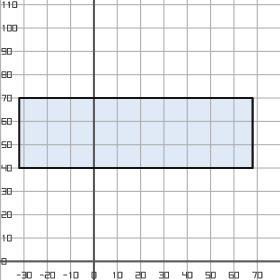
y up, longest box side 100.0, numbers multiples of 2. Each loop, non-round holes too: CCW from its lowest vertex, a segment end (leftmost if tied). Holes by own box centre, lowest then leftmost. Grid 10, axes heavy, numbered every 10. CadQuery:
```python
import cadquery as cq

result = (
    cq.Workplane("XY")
    .moveTo(-32.0, 40.0)
    .lineTo(68.0, 40.0)
    .lineTo(68.0, 70.0)
    .lineTo(-32.0, 70.0)
    .close()
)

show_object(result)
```